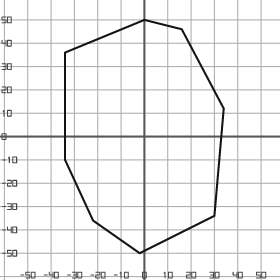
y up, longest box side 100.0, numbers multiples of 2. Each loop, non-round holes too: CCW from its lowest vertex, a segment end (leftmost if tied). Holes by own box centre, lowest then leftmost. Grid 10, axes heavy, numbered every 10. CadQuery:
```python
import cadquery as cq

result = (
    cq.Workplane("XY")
    .moveTo(-2.0, -50.0)
    .lineTo(30.0, -34.0)
    .lineTo(34.0, 12.0)
    .lineTo(16.0, 46.0)
    .lineTo(0.0, 50.0)
    .lineTo(-34.0, 36.0)
    .lineTo(-34.0, -10.0)
    .lineTo(-22.0, -36.0)
    .close()
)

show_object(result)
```